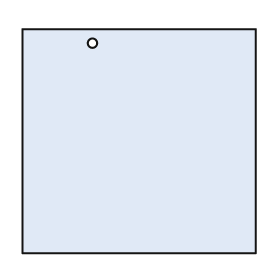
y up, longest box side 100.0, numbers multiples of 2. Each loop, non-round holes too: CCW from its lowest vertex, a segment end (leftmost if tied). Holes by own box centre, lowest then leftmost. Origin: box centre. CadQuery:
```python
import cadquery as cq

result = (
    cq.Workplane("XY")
    .moveTo(-50.0, -48.0)
    .lineTo(50.0, -48.0)
    .lineTo(50.0, 48.0)
    .lineTo(-50.0, 48.0)
    .close()
    .moveTo(-20.0, 42.0)
    .circle(2.0)
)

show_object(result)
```